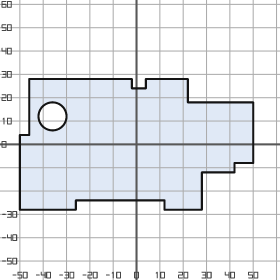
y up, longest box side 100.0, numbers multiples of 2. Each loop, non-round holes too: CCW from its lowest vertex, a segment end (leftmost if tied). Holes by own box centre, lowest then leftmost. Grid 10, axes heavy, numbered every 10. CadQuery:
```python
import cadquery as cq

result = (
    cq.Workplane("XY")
    .moveTo(-50.0, -28.0)
    .lineTo(-26.0, -28.0)
    .lineTo(-26.0, -24.0)
    .lineTo(12.0, -24.0)
    .lineTo(12.0, -28.0)
    .lineTo(28.0, -28.0)
    .lineTo(28.0, -12.0)
    .lineTo(42.0, -12.0)
    .lineTo(42.0, -8.0)
    .lineTo(50.0, -8.0)
    .lineTo(50.0, 18.0)
    .lineTo(22.0, 18.0)
    .lineTo(22.0, 28.0)
    .lineTo(4.0, 28.0)
    .lineTo(4.0, 24.0)
    .lineTo(-2.0, 24.0)
    .lineTo(-2.0, 28.0)
    .lineTo(-46.0, 28.0)
    .lineTo(-46.0, 4.0)
    .lineTo(-50.0, 4.0)
    .close()
    .moveTo(-36.0, 12.0)
    .circle(6.0)
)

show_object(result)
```